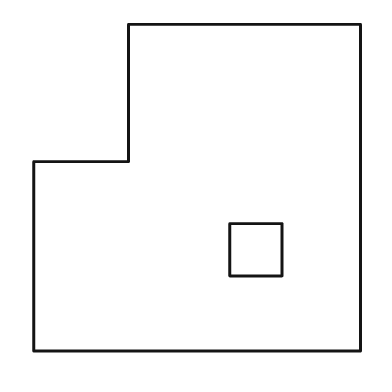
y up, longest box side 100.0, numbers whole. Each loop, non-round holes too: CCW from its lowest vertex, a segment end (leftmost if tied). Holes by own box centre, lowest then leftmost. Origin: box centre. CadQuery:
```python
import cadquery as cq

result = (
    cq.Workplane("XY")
    .moveTo(-50.0, -50.0)
    .lineTo(50.0, -50.0)
    .lineTo(50.0, 50.0)
    .lineTo(-21.0, 50.0)
    .lineTo(-21.0, 8.0)
    .lineTo(-50.0, 8.0)
    .close()
    .moveTo(10.0, -27.0)
    .lineTo(26.0, -27.0)
    .lineTo(26.0, -11.0)
    .lineTo(10.0, -11.0)
    .close()
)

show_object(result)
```